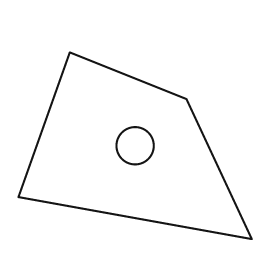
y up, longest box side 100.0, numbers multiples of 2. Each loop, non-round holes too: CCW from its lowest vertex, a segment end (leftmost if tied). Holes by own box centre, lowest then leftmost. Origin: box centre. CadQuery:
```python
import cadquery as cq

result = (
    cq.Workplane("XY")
    .moveTo(50.0, -40.0)
    .lineTo(22.0, 20.0)
    .lineTo(-28.0, 40.0)
    .lineTo(-50.0, -22.0)
    .close()
    .moveTo(0.0, 0.0)
    .circle(8.0)
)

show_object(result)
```